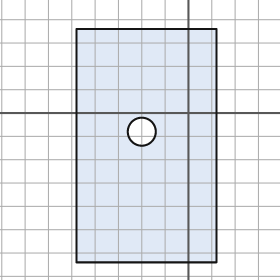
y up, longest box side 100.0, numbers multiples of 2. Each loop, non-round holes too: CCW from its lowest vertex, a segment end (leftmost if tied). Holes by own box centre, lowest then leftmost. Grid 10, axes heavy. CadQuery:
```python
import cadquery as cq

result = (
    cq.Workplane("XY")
    .moveTo(-48.0, -64.0)
    .lineTo(12.0, -64.0)
    .lineTo(12.0, 36.0)
    .lineTo(-48.0, 36.0)
    .close()
    .moveTo(-20.0, -8.0)
    .circle(6.0)
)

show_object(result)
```